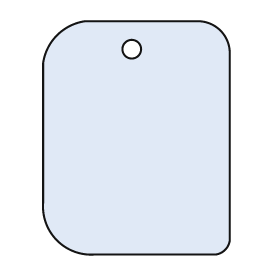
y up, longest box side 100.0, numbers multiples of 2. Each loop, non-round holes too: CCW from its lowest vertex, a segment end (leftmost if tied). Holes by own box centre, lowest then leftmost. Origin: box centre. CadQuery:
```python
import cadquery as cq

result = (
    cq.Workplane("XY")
    .moveTo(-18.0, -50.0)
    .lineTo(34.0, -50.0)
    .threePointArc((38.0, -48.0), (40.0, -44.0))
    .lineTo(40.0, 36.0)
    .threePointArc((36.0, 46.0), (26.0, 50.0))
    .lineTo(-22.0, 50.0)
    .threePointArc((-34.0, 44.0), (-40.0, 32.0))
    .lineTo(-40.0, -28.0)
    .threePointArc((-34.0, -44.0), (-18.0, -50.0))
    .close()
    .moveTo(-2.0, 38.0)
    .circle(4.0)
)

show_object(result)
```